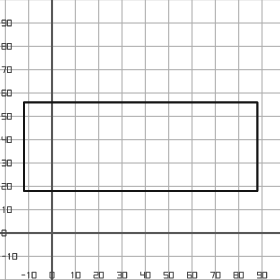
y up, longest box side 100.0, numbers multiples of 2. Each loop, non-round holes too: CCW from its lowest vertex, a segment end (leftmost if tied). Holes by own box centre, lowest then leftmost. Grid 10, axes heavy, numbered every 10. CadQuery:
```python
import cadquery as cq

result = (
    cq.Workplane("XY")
    .moveTo(-12.0, 18.0)
    .lineTo(88.0, 18.0)
    .lineTo(88.0, 56.0)
    .lineTo(-12.0, 56.0)
    .close()
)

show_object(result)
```